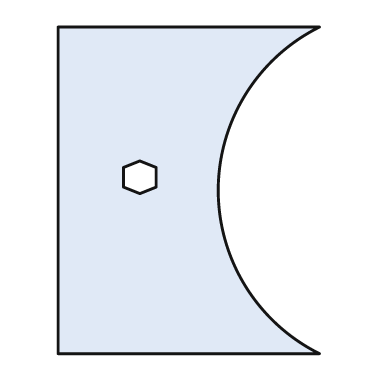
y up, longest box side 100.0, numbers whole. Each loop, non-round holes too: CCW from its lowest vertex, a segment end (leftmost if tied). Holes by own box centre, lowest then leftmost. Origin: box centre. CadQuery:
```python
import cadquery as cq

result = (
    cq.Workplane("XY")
    .moveTo(-40.0, -50.0)
    .lineTo(40.0, -50.0)
    .threePointArc((9.0, 0.0), (40.0, 50.0))
    .lineTo(-40.0, 50.0)
    .close()
    .moveTo(-15.0, -1.0)
    .lineTo(-10.0, 1.0)
    .lineTo(-10.0, 7.0)
    .lineTo(-15.0, 9.0)
    .lineTo(-20.0, 7.0)
    .lineTo(-20.0, 1.0)
    .close()
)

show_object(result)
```